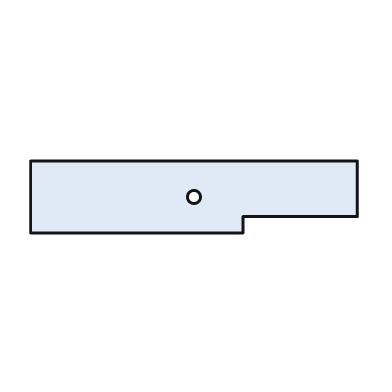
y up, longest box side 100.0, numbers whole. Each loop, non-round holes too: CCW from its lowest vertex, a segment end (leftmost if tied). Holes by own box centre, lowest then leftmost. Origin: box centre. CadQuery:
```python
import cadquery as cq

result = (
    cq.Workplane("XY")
    .moveTo(-50.0, -11.0)
    .lineTo(15.0, -11.0)
    .lineTo(15.0, -6.0)
    .lineTo(50.0, -6.0)
    .lineTo(50.0, 11.0)
    .lineTo(-50.0, 11.0)
    .close()
    .moveTo(0.0, 0.0)
    .circle(2.0)
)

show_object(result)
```